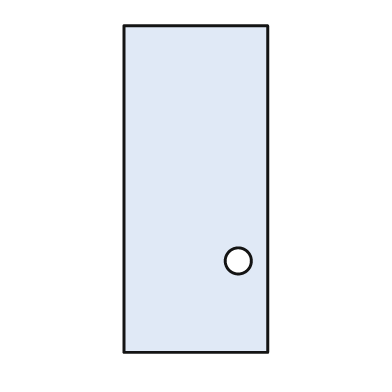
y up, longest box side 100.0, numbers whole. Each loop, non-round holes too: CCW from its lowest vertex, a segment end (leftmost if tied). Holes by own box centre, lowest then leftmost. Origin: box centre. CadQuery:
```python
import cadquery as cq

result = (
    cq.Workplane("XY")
    .moveTo(-22.0, -50.0)
    .lineTo(22.0, -50.0)
    .lineTo(22.0, 50.0)
    .lineTo(-22.0, 50.0)
    .close()
    .moveTo(13.0, -22.0)
    .circle(4.0)
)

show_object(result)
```